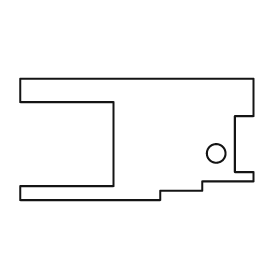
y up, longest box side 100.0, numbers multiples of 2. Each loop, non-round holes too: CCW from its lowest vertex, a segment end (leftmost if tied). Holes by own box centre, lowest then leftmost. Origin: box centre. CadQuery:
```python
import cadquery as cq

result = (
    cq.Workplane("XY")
    .moveTo(-50.0, -26.0)
    .lineTo(10.0, -26.0)
    .lineTo(10.0, -22.0)
    .lineTo(28.0, -22.0)
    .lineTo(28.0, -18.0)
    .lineTo(50.0, -18.0)
    .lineTo(50.0, -14.0)
    .lineTo(42.0, -14.0)
    .lineTo(42.0, 10.0)
    .lineTo(50.0, 10.0)
    .lineTo(50.0, 26.0)
    .lineTo(-50.0, 26.0)
    .lineTo(-50.0, 16.0)
    .lineTo(-10.0, 16.0)
    .lineTo(-10.0, -20.0)
    .lineTo(-50.0, -20.0)
    .close()
    .moveTo(34.0, -6.0)
    .circle(4.0)
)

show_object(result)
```